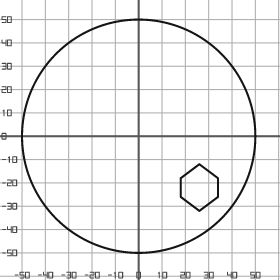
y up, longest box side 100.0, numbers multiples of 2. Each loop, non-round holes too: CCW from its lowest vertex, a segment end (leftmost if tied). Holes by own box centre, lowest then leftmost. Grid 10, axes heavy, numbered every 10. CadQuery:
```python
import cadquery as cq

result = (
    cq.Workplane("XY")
    .moveTo(0.0, 0.0)
    .circle(50.0)
    .moveTo(26.0, -32.0)
    .lineTo(34.0, -26.0)
    .lineTo(34.0, -18.0)
    .lineTo(26.0, -12.0)
    .lineTo(18.0, -18.0)
    .lineTo(18.0, -26.0)
    .close()
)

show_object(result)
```